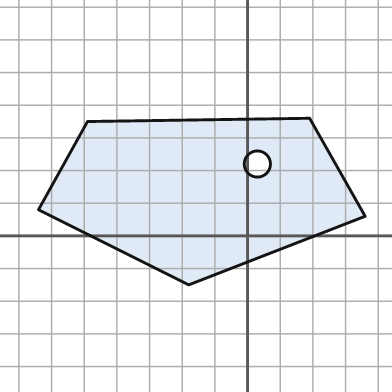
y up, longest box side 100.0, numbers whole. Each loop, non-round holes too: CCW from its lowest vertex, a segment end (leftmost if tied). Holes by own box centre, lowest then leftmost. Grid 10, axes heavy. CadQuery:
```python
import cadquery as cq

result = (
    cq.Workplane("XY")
    .moveTo(-18.0, -15.0)
    .lineTo(36.0, 6.0)
    .lineTo(19.0, 36.0)
    .lineTo(-49.0, 35.0)
    .lineTo(-64.0, 8.0)
    .close()
    .moveTo(3.0, 22.0)
    .circle(4.0)
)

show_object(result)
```